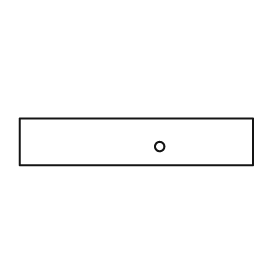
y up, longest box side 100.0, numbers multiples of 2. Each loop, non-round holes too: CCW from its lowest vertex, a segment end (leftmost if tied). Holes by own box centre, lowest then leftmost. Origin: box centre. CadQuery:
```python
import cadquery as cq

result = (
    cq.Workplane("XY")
    .moveTo(-50.0, -10.0)
    .lineTo(50.0, -10.0)
    .lineTo(50.0, 10.0)
    .lineTo(-50.0, 10.0)
    .close()
    .moveTo(10.0, -2.0)
    .circle(2.0)
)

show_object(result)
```